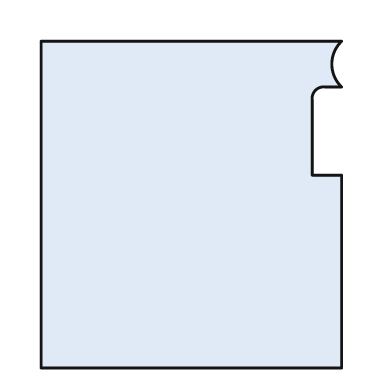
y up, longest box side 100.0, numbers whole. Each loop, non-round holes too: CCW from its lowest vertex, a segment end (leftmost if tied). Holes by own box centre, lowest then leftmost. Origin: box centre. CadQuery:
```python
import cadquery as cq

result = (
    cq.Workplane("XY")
    .moveTo(-46.0, -50.0)
    .lineTo(46.0, -50.0)
    .lineTo(46.0, 9.0)
    .lineTo(37.0, 9.0)
    .lineTo(37.0, 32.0)
    .threePointArc((38.0, 35.0), (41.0, 36.0))
    .lineTo(46.0, 36.0)
    .threePointArc((43.0, 43.0), (46.0, 50.0))
    .lineTo(-46.0, 50.0)
    .close()
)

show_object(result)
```